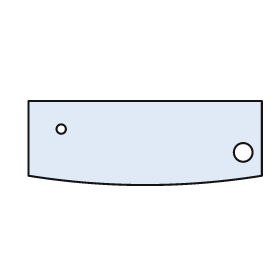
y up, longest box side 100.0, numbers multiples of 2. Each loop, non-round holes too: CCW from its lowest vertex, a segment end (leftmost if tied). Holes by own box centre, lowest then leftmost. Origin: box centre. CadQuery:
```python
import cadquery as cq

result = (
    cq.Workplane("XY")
    .moveTo(-50.0, -14.0)
    .threePointArc((0.0, -18.0), (50.0, -14.0))
    .lineTo(50.0, 18.0)
    .lineTo(-50.0, 18.0)
    .close()
    .moveTo(42.0, -4.0)
    .circle(4.0)
    .moveTo(-36.0, 6.0)
    .circle(2.0)
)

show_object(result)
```